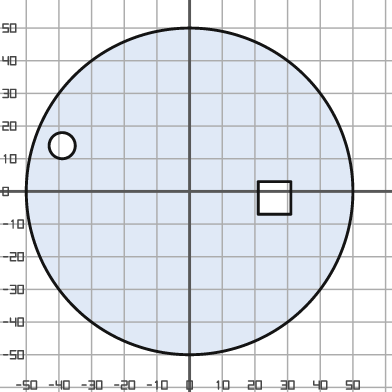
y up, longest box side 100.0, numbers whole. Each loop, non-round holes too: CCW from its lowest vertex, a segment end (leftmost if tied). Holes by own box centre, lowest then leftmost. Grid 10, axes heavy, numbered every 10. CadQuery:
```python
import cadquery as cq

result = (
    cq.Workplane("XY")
    .moveTo(0.0, 0.0)
    .circle(50.0)
    .moveTo(21.0, -7.0)
    .lineTo(31.0, -7.0)
    .lineTo(31.0, 3.0)
    .lineTo(21.0, 3.0)
    .close()
    .moveTo(-39.0, 14.0)
    .circle(4.0)
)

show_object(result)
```